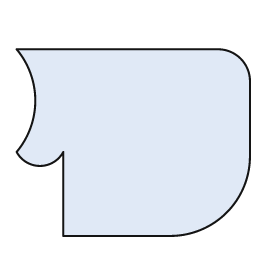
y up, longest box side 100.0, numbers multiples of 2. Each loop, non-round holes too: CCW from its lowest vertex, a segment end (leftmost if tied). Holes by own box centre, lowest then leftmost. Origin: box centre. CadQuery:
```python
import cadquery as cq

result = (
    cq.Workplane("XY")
    .moveTo(-30.0, -40.0)
    .lineTo(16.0, -40.0)
    .threePointArc((40.0, -30.0), (50.0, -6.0))
    .lineTo(50.0, 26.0)
    .threePointArc((46.0, 36.0), (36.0, 40.0))
    .lineTo(-50.0, 40.0)
    .threePointArc((-42.0, 18.0), (-50.0, -4.0))
    .threePointArc((-40.0, -10.0), (-30.0, -4.0))
    .close()
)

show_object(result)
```